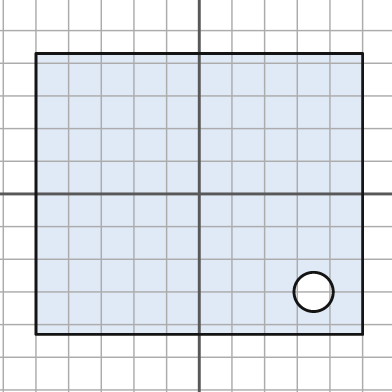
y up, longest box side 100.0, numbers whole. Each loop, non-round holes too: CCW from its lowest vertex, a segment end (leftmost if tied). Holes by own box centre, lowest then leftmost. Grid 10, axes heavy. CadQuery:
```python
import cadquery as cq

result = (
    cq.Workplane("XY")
    .moveTo(-50.0, -43.0)
    .lineTo(50.0, -43.0)
    .lineTo(50.0, 43.0)
    .lineTo(-50.0, 43.0)
    .close()
    .moveTo(35.0, -30.0)
    .circle(6.0)
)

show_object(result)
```